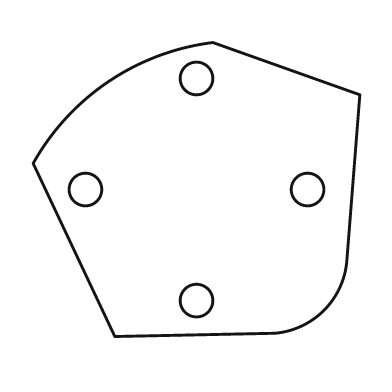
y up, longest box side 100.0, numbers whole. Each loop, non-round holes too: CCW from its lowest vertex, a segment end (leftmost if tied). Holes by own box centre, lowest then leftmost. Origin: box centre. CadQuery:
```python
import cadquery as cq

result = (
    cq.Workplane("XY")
    .moveTo(-25.0, -45.0)
    .lineTo(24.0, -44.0)
    .threePointArc((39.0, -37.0), (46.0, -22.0))
    .lineTo(50.0, 29.0)
    .lineTo(5.0, 45.0)
    .threePointArc((-27.0, 33.0), (-50.0, 8.0))
    .close()
    .moveTo(0.0, -34.0)
    .circle(5.0)
    .moveTo(-34.0, 0.0)
    .circle(5.0)
    .moveTo(34.0, 0.0)
    .circle(5.0)
    .moveTo(0.0, 34.0)
    .circle(5.0)
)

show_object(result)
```